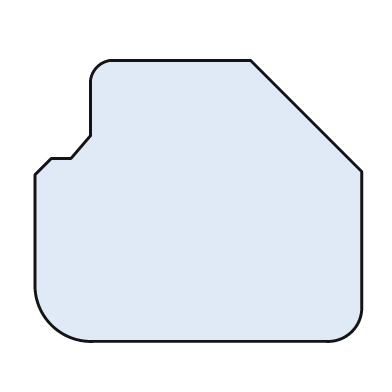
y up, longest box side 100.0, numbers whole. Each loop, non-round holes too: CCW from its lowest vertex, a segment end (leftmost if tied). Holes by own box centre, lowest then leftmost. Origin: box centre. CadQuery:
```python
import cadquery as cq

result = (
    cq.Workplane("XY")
    .moveTo(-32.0, -43.0)
    .lineTo(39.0, -43.0)
    .threePointArc((47.0, -40.0), (50.0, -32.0))
    .lineTo(50.0, 9.0)
    .lineTo(16.0, 43.0)
    .lineTo(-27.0, 43.0)
    .threePointArc((-31.0, 41.0), (-33.0, 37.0))
    .lineTo(-33.0, 20.0)
    .lineTo(-39.0, 13.0)
    .lineTo(-45.0, 13.0)
    .lineTo(-50.0, 8.0)
    .lineTo(-50.0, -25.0)
    .threePointArc((-45.0, -38.0), (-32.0, -43.0))
    .close()
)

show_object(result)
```